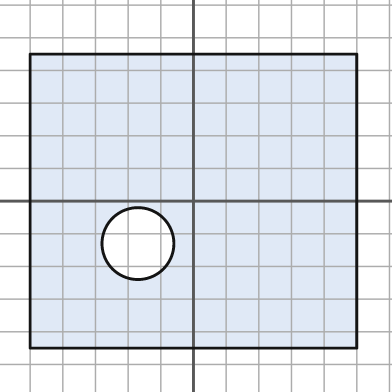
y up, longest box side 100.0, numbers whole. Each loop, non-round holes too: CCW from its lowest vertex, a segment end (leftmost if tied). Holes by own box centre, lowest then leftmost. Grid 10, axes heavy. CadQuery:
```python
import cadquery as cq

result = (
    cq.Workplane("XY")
    .moveTo(-50.0, -45.0)
    .lineTo(50.0, -45.0)
    .lineTo(50.0, 45.0)
    .lineTo(-50.0, 45.0)
    .close()
    .moveTo(-17.0, -13.0)
    .circle(11.0)
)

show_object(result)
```